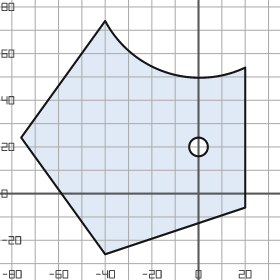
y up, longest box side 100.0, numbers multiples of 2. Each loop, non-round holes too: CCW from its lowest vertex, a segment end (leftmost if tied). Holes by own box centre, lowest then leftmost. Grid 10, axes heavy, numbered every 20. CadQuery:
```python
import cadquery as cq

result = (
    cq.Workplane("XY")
    .moveTo(-40.0, -26.0)
    .lineTo(20.0, -6.0)
    .lineTo(20.0, 54.0)
    .threePointArc((-14.0, 52.0), (-40.0, 74.0))
    .lineTo(-76.0, 24.0)
    .close()
    .moveTo(0.0, 20.0)
    .circle(4.0)
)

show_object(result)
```